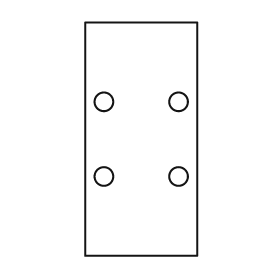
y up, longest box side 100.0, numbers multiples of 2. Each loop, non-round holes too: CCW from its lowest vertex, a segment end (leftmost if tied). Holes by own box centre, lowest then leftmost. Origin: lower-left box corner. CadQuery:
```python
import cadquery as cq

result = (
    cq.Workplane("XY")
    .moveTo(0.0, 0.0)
    .lineTo(48.0, 0.0)
    .lineTo(48.0, 100.0)
    .lineTo(0.0, 100.0)
    .close()
    .moveTo(8.0, 34.0)
    .circle(4.0)
    .moveTo(40.0, 34.0)
    .circle(4.0)
    .moveTo(8.0, 66.0)
    .circle(4.0)
    .moveTo(40.0, 66.0)
    .circle(4.0)
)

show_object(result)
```